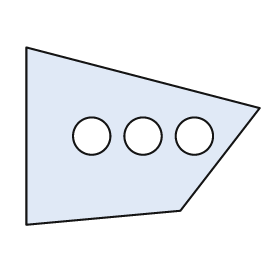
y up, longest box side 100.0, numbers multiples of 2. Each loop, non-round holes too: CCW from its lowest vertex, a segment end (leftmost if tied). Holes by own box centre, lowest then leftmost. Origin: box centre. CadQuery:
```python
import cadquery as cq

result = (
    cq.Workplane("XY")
    .moveTo(-50.0, -38.0)
    .lineTo(16.0, -32.0)
    .lineTo(50.0, 12.0)
    .lineTo(-50.0, 38.0)
    .close()
    .moveTo(-22.0, 0.0)
    .circle(8.0)
    .moveTo(0.0, 0.0)
    .circle(8.0)
    .moveTo(22.0, 0.0)
    .circle(8.0)
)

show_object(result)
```